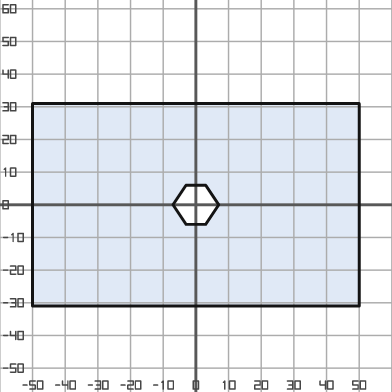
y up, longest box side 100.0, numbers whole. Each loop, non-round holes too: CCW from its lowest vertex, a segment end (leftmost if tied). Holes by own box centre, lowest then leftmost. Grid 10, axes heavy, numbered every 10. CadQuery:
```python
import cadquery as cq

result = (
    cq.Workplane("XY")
    .moveTo(-50.0, -31.0)
    .lineTo(50.0, -31.0)
    .lineTo(50.0, 31.0)
    .lineTo(-50.0, 31.0)
    .close()
    .moveTo(-3.0, -6.0)
    .lineTo(3.0, -6.0)
    .lineTo(7.0, 0.0)
    .lineTo(3.0, 6.0)
    .lineTo(-3.0, 6.0)
    .lineTo(-7.0, 0.0)
    .close()
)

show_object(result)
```